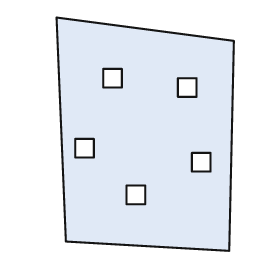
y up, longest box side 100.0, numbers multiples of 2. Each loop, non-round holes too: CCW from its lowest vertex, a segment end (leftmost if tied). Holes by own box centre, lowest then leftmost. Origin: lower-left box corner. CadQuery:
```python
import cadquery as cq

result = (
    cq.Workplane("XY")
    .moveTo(74.0, 0.0)
    .lineTo(76.0, 90.0)
    .lineTo(0.0, 100.0)
    .lineTo(4.0, 4.0)
    .close()
    .moveTo(30.0, 20.0)
    .lineTo(38.0, 20.0)
    .lineTo(38.0, 28.0)
    .lineTo(30.0, 28.0)
    .close()
    .moveTo(58.0, 34.0)
    .lineTo(66.0, 34.0)
    .lineTo(66.0, 42.0)
    .lineTo(58.0, 42.0)
    .close()
    .moveTo(8.0, 40.0)
    .lineTo(16.0, 40.0)
    .lineTo(16.0, 48.0)
    .lineTo(8.0, 48.0)
    .close()
    .moveTo(52.0, 66.0)
    .lineTo(60.0, 66.0)
    .lineTo(60.0, 74.0)
    .lineTo(52.0, 74.0)
    .close()
    .moveTo(20.0, 70.0)
    .lineTo(28.0, 70.0)
    .lineTo(28.0, 78.0)
    .lineTo(20.0, 78.0)
    .close()
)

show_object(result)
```